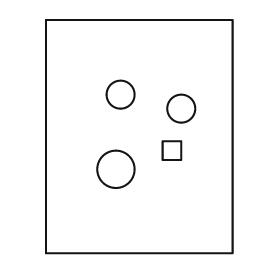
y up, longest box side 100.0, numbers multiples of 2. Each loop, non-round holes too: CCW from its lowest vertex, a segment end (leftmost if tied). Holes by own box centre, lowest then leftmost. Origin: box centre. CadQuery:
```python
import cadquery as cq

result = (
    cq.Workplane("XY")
    .moveTo(-40.0, -50.0)
    .lineTo(40.0, -50.0)
    .lineTo(40.0, 50.0)
    .lineTo(-40.0, 50.0)
    .close()
    .moveTo(-10.0, -14.0)
    .circle(8.0)
    .moveTo(10.0, -10.0)
    .lineTo(18.0, -10.0)
    .lineTo(18.0, -2.0)
    .lineTo(10.0, -2.0)
    .close()
    .moveTo(18.0, 12.0)
    .circle(6.0)
    .moveTo(-8.0, 18.0)
    .circle(6.0)
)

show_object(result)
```